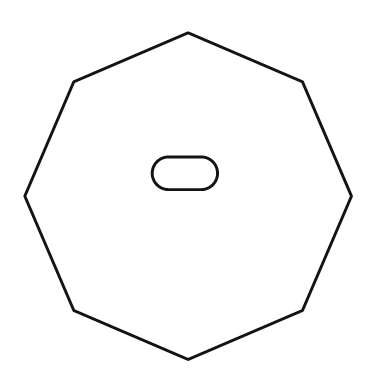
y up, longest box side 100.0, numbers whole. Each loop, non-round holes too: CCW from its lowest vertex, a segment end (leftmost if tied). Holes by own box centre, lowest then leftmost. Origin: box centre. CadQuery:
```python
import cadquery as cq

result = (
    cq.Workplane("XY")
    .moveTo(0.0, -50.0)
    .lineTo(35.0, -35.0)
    .lineTo(50.0, 0.0)
    .lineTo(35.0, 35.0)
    .lineTo(0.0, 50.0)
    .lineTo(-35.0, 35.0)
    .lineTo(-50.0, 0.0)
    .lineTo(-35.0, -35.0)
    .close()
    .moveTo(-6.0, 2.0)
    .lineTo(4.0, 2.0)
    .threePointArc((9.0, 7.0), (4.0, 12.0))
    .lineTo(-6.0, 12.0)
    .threePointArc((-11.0, 7.0), (-6.0, 2.0))
    .close()
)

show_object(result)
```